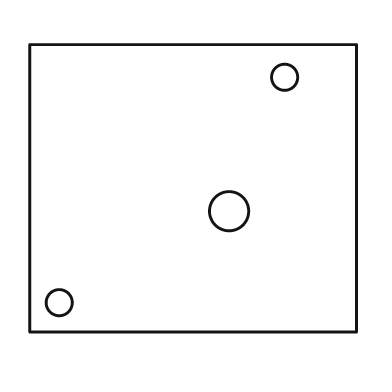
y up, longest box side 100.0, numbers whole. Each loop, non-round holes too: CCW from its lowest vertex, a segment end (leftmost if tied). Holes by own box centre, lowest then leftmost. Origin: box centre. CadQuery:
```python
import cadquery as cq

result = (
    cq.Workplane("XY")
    .moveTo(-50.0, -44.0)
    .lineTo(50.0, -44.0)
    .lineTo(50.0, 44.0)
    .lineTo(-50.0, 44.0)
    .close()
    .moveTo(-41.0, -35.0)
    .circle(4.0)
    .moveTo(11.0, -7.0)
    .circle(6.0)
    .moveTo(28.0, 34.0)
    .circle(4.0)
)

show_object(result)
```